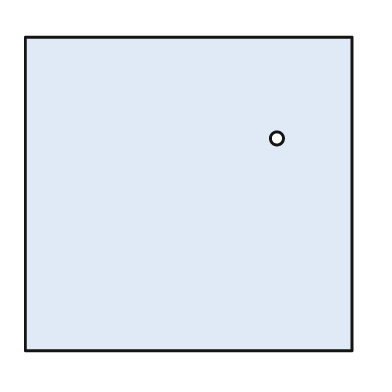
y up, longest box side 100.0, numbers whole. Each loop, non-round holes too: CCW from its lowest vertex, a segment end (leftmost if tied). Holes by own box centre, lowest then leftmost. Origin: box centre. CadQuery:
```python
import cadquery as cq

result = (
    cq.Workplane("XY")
    .moveTo(-50.0, -48.0)
    .lineTo(50.0, -48.0)
    .lineTo(50.0, 48.0)
    .lineTo(-50.0, 48.0)
    .close()
    .moveTo(27.0, 17.0)
    .circle(2.0)
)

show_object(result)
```